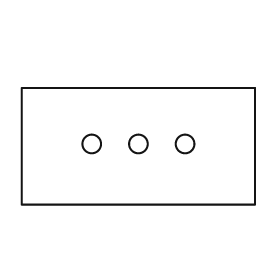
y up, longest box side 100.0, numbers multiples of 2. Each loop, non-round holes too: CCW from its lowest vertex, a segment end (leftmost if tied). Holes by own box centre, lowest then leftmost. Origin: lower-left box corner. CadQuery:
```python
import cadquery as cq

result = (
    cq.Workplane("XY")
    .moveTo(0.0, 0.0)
    .lineTo(100.0, 0.0)
    .lineTo(100.0, 50.0)
    .lineTo(0.0, 50.0)
    .close()
    .moveTo(30.0, 26.0)
    .circle(4.0)
    .moveTo(50.0, 26.0)
    .circle(4.0)
    .moveTo(70.0, 26.0)
    .circle(4.0)
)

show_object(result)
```